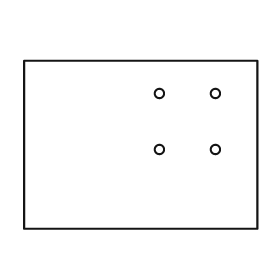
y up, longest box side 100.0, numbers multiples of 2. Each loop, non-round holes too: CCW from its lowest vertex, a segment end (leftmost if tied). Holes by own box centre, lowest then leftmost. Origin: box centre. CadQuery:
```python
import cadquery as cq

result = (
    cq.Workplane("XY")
    .moveTo(-50.0, -36.0)
    .lineTo(50.0, -36.0)
    .lineTo(50.0, 36.0)
    .lineTo(-50.0, 36.0)
    .close()
    .moveTo(8.0, -2.0)
    .circle(2.0)
    .moveTo(32.0, -2.0)
    .circle(2.0)
    .moveTo(8.0, 22.0)
    .circle(2.0)
    .moveTo(32.0, 22.0)
    .circle(2.0)
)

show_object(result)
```